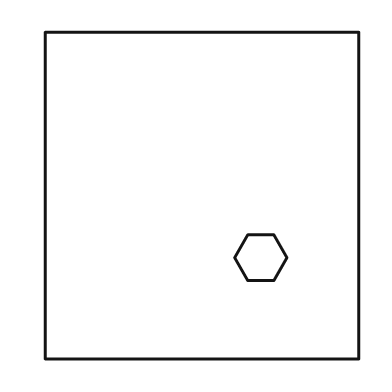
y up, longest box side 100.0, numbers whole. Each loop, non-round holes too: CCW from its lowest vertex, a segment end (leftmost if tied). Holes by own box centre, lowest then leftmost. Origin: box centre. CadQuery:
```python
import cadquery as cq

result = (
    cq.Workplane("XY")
    .moveTo(-48.0, -50.0)
    .lineTo(48.0, -50.0)
    .lineTo(48.0, 50.0)
    .lineTo(-48.0, 50.0)
    .close()
    .moveTo(14.0, -26.0)
    .lineTo(22.0, -26.0)
    .lineTo(26.0, -19.0)
    .lineTo(22.0, -12.0)
    .lineTo(14.0, -12.0)
    .lineTo(10.0, -19.0)
    .close()
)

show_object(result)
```